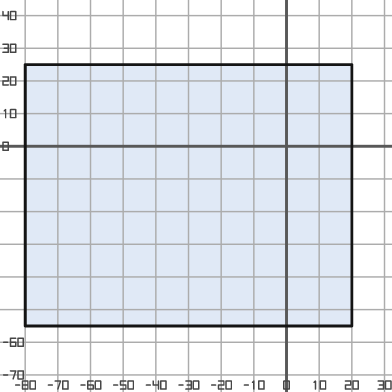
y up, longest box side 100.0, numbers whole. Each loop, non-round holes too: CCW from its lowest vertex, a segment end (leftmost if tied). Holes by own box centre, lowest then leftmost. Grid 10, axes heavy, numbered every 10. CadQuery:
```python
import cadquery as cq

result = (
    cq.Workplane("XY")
    .moveTo(-80.0, -55.0)
    .lineTo(20.0, -55.0)
    .lineTo(20.0, 25.0)
    .lineTo(-80.0, 25.0)
    .close()
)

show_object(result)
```